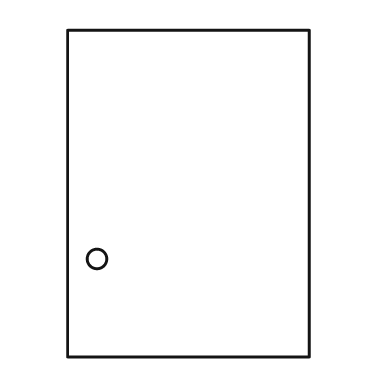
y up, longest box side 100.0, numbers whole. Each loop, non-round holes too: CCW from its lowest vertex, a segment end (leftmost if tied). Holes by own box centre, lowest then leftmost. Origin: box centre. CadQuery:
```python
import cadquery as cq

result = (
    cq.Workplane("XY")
    .moveTo(-37.0, -50.0)
    .lineTo(37.0, -50.0)
    .lineTo(37.0, 50.0)
    .lineTo(-37.0, 50.0)
    .close()
    .moveTo(-28.0, -20.0)
    .circle(3.0)
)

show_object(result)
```